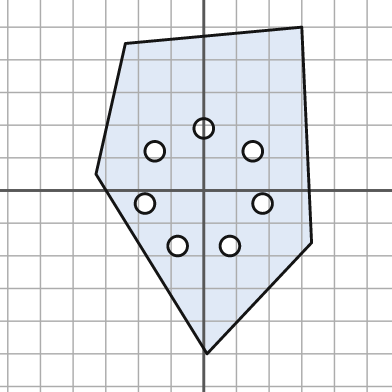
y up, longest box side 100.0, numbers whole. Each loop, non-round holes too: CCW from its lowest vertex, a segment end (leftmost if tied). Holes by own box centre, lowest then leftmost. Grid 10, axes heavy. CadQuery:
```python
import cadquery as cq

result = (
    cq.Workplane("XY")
    .moveTo(1.0, -50.0)
    .lineTo(33.0, -16.0)
    .lineTo(30.0, 50.0)
    .lineTo(-24.0, 45.0)
    .lineTo(-33.0, 5.0)
    .close()
    .moveTo(-8.0, -17.0)
    .circle(3.0)
    .moveTo(8.0, -17.0)
    .circle(3.0)
    .moveTo(-18.0, -4.0)
    .circle(3.0)
    .moveTo(18.0, -4.0)
    .circle(3.0)
    .moveTo(-15.0, 12.0)
    .circle(3.0)
    .moveTo(15.0, 12.0)
    .circle(3.0)
    .moveTo(0.0, 19.0)
    .circle(3.0)
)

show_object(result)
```